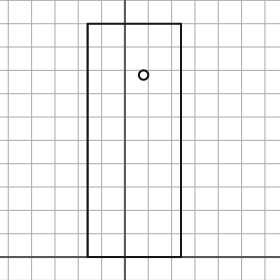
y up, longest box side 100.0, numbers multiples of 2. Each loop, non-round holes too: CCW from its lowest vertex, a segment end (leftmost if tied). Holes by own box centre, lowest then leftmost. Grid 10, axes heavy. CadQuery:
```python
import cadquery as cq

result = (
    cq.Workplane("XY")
    .moveTo(-16.0, 0.0)
    .lineTo(24.0, 0.0)
    .lineTo(24.0, 100.0)
    .lineTo(-16.0, 100.0)
    .close()
    .moveTo(8.0, 78.0)
    .circle(2.0)
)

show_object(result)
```